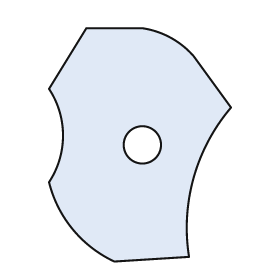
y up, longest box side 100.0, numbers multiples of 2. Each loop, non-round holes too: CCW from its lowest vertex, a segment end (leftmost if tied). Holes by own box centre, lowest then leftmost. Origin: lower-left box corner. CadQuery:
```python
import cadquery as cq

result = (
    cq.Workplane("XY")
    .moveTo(28.0, 0.0)
    .lineTo(60.0, 2.0)
    .threePointArc((62.0, 36.0), (78.0, 66.0))
    .lineTo(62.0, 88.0)
    .threePointArc((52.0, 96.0), (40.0, 100.0))
    .lineTo(16.0, 100.0)
    .lineTo(0.0, 74.0)
    .threePointArc((6.0, 54.0), (0.0, 34.0))
    .threePointArc((10.0, 14.0), (28.0, 0.0))
    .close()
    .moveTo(40.0, 50.0)
    .circle(8.0)
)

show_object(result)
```